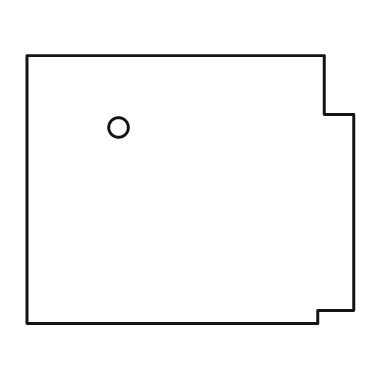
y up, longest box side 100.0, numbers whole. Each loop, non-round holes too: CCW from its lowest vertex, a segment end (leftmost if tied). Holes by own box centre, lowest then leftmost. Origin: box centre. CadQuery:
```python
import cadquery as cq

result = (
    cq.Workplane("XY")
    .moveTo(-50.0, -41.0)
    .lineTo(39.0, -41.0)
    .lineTo(39.0, -37.0)
    .lineTo(50.0, -37.0)
    .lineTo(50.0, 23.0)
    .lineTo(41.0, 23.0)
    .lineTo(41.0, 41.0)
    .lineTo(-50.0, 41.0)
    .close()
    .moveTo(-22.0, 19.0)
    .circle(3.0)
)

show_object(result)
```